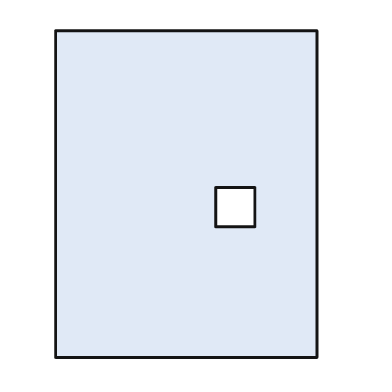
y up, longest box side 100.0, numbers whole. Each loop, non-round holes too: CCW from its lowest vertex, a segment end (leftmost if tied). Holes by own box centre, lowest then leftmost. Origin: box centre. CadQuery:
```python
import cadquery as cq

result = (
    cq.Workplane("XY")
    .moveTo(-40.0, -50.0)
    .lineTo(40.0, -50.0)
    .lineTo(40.0, 50.0)
    .lineTo(-40.0, 50.0)
    .close()
    .moveTo(9.0, -10.0)
    .lineTo(21.0, -10.0)
    .lineTo(21.0, 2.0)
    .lineTo(9.0, 2.0)
    .close()
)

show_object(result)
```